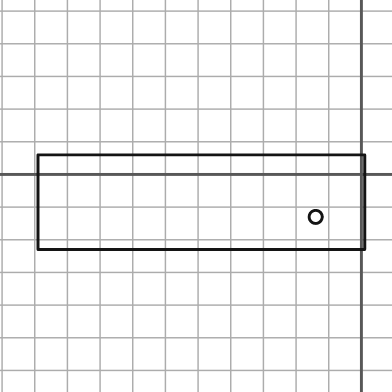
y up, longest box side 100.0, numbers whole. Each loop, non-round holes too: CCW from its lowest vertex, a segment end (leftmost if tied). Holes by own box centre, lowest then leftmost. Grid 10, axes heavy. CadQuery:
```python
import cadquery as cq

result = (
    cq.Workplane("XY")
    .moveTo(-99.0, -23.0)
    .lineTo(1.0, -23.0)
    .lineTo(1.0, 6.0)
    .lineTo(-99.0, 6.0)
    .close()
    .moveTo(-14.0, -13.0)
    .circle(2.0)
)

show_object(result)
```